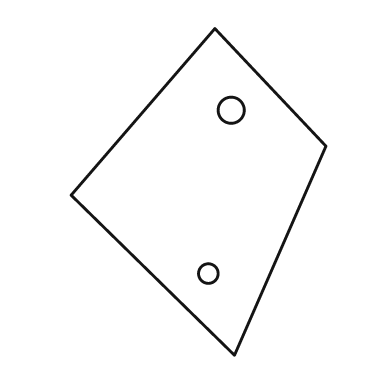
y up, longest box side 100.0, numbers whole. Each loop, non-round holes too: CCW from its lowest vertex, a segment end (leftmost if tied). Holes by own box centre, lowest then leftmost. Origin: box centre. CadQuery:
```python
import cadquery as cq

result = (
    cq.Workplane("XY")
    .moveTo(11.0, -50.0)
    .lineTo(39.0, 14.0)
    .lineTo(5.0, 50.0)
    .lineTo(-39.0, -1.0)
    .close()
    .moveTo(3.0, -25.0)
    .circle(3.0)
    .moveTo(10.0, 25.0)
    .circle(4.0)
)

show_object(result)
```